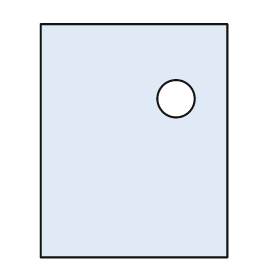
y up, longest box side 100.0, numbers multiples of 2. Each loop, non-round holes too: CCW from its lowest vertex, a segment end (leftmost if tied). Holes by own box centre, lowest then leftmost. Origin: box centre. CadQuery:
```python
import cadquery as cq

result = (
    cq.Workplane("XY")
    .moveTo(-40.0, -50.0)
    .lineTo(40.0, -50.0)
    .lineTo(40.0, 50.0)
    .lineTo(-40.0, 50.0)
    .close()
    .moveTo(18.0, 18.0)
    .circle(8.0)
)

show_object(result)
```